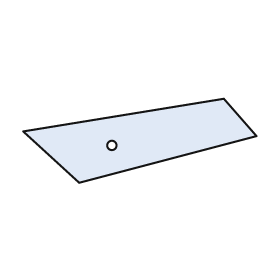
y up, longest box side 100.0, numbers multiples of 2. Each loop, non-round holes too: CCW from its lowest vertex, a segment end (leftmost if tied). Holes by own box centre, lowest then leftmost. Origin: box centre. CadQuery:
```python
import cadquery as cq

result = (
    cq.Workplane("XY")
    .moveTo(-26.0, -18.0)
    .lineTo(50.0, 2.0)
    .lineTo(36.0, 18.0)
    .lineTo(-50.0, 4.0)
    .close()
    .moveTo(-12.0, -2.0)
    .circle(2.0)
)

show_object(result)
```